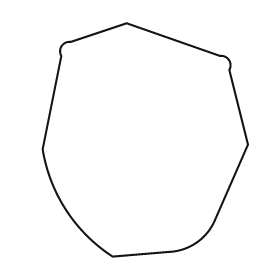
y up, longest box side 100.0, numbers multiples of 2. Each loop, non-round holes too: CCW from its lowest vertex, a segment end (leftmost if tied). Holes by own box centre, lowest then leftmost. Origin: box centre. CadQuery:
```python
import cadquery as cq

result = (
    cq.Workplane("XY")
    .moveTo(-14.0, -50.0)
    .lineTo(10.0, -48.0)
    .threePointArc((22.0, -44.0), (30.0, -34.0))
    .lineTo(44.0, -2.0)
    .lineTo(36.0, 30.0)
    .threePointArc((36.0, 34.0), (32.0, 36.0))
    .lineTo(-8.0, 50.0)
    .lineTo(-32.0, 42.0)
    .threePointArc((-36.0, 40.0), (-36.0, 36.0))
    .lineTo(-44.0, -4.0)
    .threePointArc((-34.0, -30.0), (-14.0, -50.0))
    .close()
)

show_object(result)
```